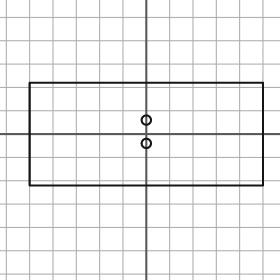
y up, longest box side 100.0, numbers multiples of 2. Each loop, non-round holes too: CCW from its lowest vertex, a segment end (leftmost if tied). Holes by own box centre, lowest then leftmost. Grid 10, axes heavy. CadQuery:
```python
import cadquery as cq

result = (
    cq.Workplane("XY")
    .moveTo(-50.0, -22.0)
    .lineTo(50.0, -22.0)
    .lineTo(50.0, 22.0)
    .lineTo(-50.0, 22.0)
    .close()
    .moveTo(0.0, -4.0)
    .circle(2.0)
    .moveTo(0.0, 6.0)
    .circle(2.0)
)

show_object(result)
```